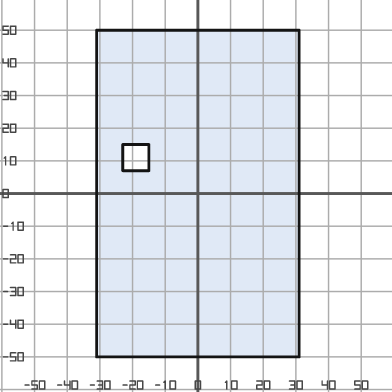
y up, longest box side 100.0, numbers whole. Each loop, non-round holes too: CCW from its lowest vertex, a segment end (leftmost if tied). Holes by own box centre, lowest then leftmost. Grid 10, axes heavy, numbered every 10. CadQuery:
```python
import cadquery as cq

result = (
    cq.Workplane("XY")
    .moveTo(-31.0, -50.0)
    .lineTo(31.0, -50.0)
    .lineTo(31.0, 50.0)
    .lineTo(-31.0, 50.0)
    .close()
    .moveTo(-23.0, 7.0)
    .lineTo(-15.0, 7.0)
    .lineTo(-15.0, 15.0)
    .lineTo(-23.0, 15.0)
    .close()
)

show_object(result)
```